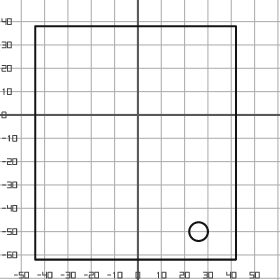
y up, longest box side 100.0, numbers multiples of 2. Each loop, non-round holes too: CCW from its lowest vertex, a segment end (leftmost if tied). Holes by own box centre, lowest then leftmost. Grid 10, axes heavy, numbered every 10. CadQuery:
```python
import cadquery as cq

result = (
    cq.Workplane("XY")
    .moveTo(-44.0, -62.0)
    .lineTo(42.0, -62.0)
    .lineTo(42.0, 38.0)
    .lineTo(-44.0, 38.0)
    .close()
    .moveTo(26.0, -50.0)
    .circle(4.0)
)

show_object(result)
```